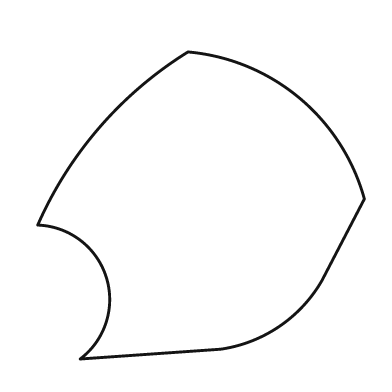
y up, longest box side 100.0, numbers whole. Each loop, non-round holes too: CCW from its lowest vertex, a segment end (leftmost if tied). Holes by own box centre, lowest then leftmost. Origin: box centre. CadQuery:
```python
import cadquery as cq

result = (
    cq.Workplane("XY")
    .moveTo(-37.0, -47.0)
    .lineTo(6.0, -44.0)
    .threePointArc((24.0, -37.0), (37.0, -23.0))
    .lineTo(50.0, 2.0)
    .threePointArc((30.0, 33.0), (-4.0, 47.0))
    .threePointArc((-31.0, 24.0), (-50.0, -6.0))
    .threePointArc((-29.0, -22.0), (-37.0, -47.0))
    .close()
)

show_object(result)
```